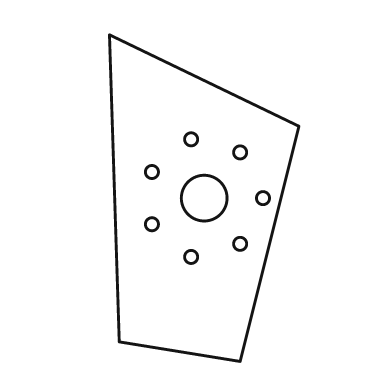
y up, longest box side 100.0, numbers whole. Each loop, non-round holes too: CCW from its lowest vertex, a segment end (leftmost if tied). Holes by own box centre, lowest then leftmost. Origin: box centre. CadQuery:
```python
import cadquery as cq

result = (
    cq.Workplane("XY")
    .moveTo(11.0, -50.0)
    .lineTo(29.0, 22.0)
    .lineTo(-29.0, 50.0)
    .lineTo(-26.0, -44.0)
    .close()
    .moveTo(-4.0, -18.0)
    .circle(2.0)
    .moveTo(11.0, -14.0)
    .circle(2.0)
    .moveTo(-16.0, -8.0)
    .circle(2.0)
    .moveTo(0.0, 0.0)
    .circle(7.0)
    .moveTo(18.0, 0.0)
    .circle(2.0)
    .moveTo(-16.0, 8.0)
    .circle(2.0)
    .moveTo(11.0, 14.0)
    .circle(2.0)
    .moveTo(-4.0, 18.0)
    .circle(2.0)
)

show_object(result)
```